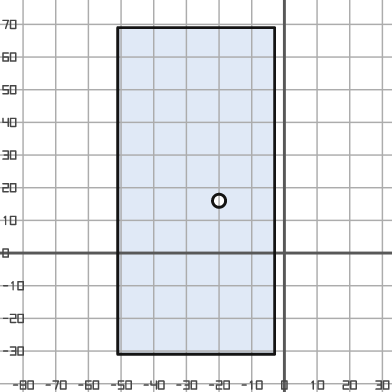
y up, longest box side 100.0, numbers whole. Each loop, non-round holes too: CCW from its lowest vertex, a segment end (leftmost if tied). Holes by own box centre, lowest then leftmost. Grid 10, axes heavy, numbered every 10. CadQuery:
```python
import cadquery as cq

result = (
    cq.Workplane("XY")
    .moveTo(-51.0, -31.0)
    .lineTo(-3.0, -31.0)
    .lineTo(-3.0, 69.0)
    .lineTo(-51.0, 69.0)
    .close()
    .moveTo(-20.0, 16.0)
    .circle(2.0)
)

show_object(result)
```